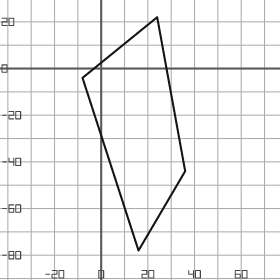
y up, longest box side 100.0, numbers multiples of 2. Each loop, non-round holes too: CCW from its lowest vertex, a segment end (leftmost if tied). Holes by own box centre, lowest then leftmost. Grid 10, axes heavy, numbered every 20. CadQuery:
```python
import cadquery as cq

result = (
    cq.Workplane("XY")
    .moveTo(16.0, -78.0)
    .lineTo(36.0, -44.0)
    .lineTo(24.0, 22.0)
    .lineTo(-8.0, -4.0)
    .close()
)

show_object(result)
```